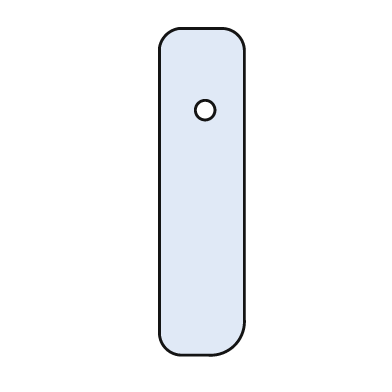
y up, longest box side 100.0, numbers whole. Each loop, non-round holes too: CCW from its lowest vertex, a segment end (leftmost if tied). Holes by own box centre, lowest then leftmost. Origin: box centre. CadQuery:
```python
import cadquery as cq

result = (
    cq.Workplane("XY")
    .moveTo(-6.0, -50.0)
    .lineTo(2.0, -50.0)
    .threePointArc((10.0, -47.0), (13.0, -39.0))
    .lineTo(13.0, 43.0)
    .threePointArc((11.0, 48.0), (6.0, 50.0))
    .lineTo(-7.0, 50.0)
    .threePointArc((-11.0, 48.0), (-13.0, 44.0))
    .lineTo(-13.0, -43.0)
    .threePointArc((-11.0, -48.0), (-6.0, -50.0))
    .close()
    .moveTo(1.0, 25.0)
    .circle(3.0)
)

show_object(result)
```